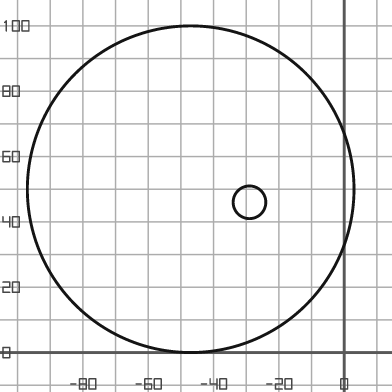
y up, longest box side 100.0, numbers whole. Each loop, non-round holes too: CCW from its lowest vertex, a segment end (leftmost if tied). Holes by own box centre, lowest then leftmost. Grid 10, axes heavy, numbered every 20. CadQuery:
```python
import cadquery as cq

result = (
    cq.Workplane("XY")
    .moveTo(-47.0, 50.0)
    .circle(50.0)
    .moveTo(-29.0, 46.0)
    .circle(5.0)
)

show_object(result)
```